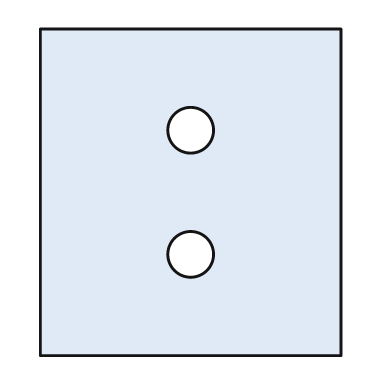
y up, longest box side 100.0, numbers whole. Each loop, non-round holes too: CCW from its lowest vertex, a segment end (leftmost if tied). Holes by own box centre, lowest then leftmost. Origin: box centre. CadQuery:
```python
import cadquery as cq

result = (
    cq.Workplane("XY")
    .moveTo(-46.0, -50.0)
    .lineTo(46.0, -50.0)
    .lineTo(46.0, 50.0)
    .lineTo(-46.0, 50.0)
    .close()
    .moveTo(0.0, -19.0)
    .circle(7.0)
    .moveTo(0.0, 19.0)
    .circle(7.0)
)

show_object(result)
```